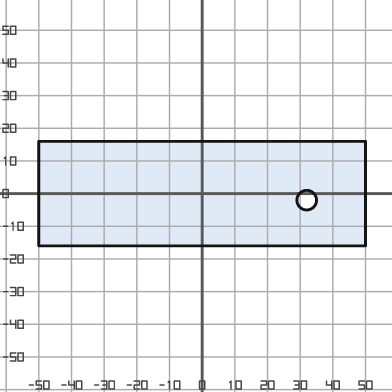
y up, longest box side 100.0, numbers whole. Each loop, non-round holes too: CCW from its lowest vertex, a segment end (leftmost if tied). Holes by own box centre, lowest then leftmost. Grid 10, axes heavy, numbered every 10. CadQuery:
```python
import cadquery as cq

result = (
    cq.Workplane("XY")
    .moveTo(-50.0, -16.0)
    .lineTo(50.0, -16.0)
    .lineTo(50.0, 16.0)
    .lineTo(-50.0, 16.0)
    .close()
    .moveTo(32.0, -2.0)
    .circle(3.0)
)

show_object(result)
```